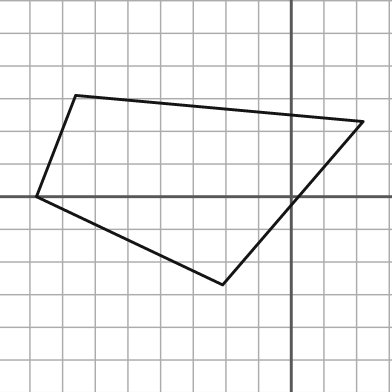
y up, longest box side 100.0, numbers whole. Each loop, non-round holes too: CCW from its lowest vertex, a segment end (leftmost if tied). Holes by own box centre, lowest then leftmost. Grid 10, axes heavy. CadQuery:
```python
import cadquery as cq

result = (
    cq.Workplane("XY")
    .moveTo(-21.0, -27.0)
    .lineTo(22.0, 23.0)
    .lineTo(-66.0, 31.0)
    .lineTo(-78.0, 0.0)
    .close()
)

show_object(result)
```